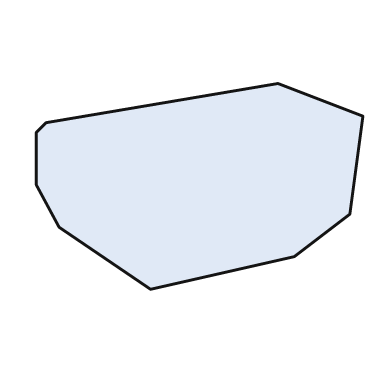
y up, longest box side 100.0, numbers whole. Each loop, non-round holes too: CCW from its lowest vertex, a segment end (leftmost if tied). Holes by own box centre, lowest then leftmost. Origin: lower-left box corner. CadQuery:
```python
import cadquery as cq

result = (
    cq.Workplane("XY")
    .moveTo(35.0, 0.0)
    .lineTo(79.0, 10.0)
    .lineTo(96.0, 23.0)
    .lineTo(100.0, 53.0)
    .lineTo(74.0, 63.0)
    .lineTo(3.0, 51.0)
    .lineTo(0.0, 48.0)
    .lineTo(0.0, 32.0)
    .lineTo(7.0, 19.0)
    .close()
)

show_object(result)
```